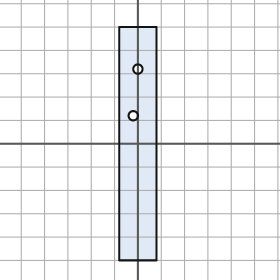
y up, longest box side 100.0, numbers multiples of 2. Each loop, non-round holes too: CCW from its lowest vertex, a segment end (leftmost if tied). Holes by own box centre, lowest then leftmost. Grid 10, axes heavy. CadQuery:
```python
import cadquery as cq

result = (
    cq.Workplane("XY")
    .moveTo(-8.0, -50.0)
    .lineTo(8.0, -50.0)
    .lineTo(8.0, 50.0)
    .lineTo(-8.0, 50.0)
    .close()
    .moveTo(-2.0, 12.0)
    .circle(2.0)
    .moveTo(0.0, 32.0)
    .circle(2.0)
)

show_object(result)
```